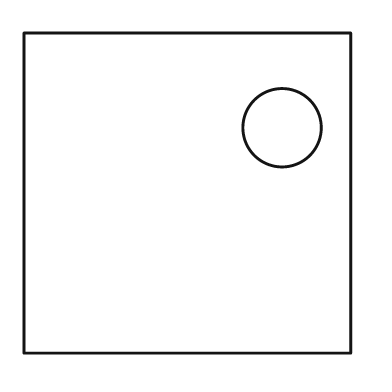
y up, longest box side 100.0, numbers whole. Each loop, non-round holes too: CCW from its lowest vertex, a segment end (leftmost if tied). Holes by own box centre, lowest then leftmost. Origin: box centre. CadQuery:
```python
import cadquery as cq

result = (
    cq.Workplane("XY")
    .moveTo(-50.0, -49.0)
    .lineTo(50.0, -49.0)
    .lineTo(50.0, 49.0)
    .lineTo(-50.0, 49.0)
    .close()
    .moveTo(29.0, 20.0)
    .circle(12.0)
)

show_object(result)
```